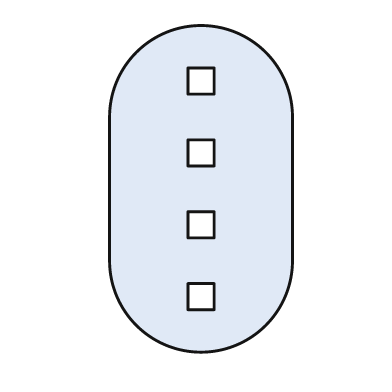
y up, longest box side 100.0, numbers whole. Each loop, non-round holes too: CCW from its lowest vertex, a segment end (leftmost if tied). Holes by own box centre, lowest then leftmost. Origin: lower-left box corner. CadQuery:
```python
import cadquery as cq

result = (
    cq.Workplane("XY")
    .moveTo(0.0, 28.0)
    .threePointArc((28.0, 0.0), (56.0, 28.0))
    .lineTo(56.0, 72.0)
    .threePointArc((28.0, 100.0), (0.0, 72.0))
    .close()
    .moveTo(24.0, 13.0)
    .lineTo(32.0, 13.0)
    .lineTo(32.0, 21.0)
    .lineTo(24.0, 21.0)
    .close()
    .moveTo(24.0, 35.0)
    .lineTo(32.0, 35.0)
    .lineTo(32.0, 43.0)
    .lineTo(24.0, 43.0)
    .close()
    .moveTo(24.0, 57.0)
    .lineTo(32.0, 57.0)
    .lineTo(32.0, 65.0)
    .lineTo(24.0, 65.0)
    .close()
    .moveTo(24.0, 79.0)
    .lineTo(32.0, 79.0)
    .lineTo(32.0, 87.0)
    .lineTo(24.0, 87.0)
    .close()
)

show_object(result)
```